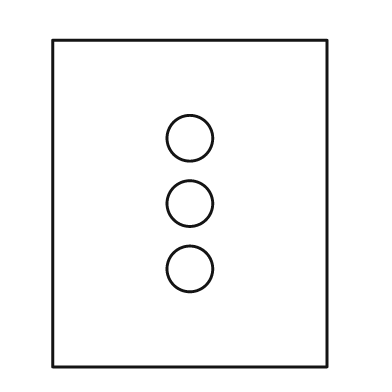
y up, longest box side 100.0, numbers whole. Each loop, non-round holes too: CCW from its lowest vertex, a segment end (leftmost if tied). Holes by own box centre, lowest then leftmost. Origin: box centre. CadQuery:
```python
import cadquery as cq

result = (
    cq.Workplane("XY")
    .moveTo(-42.0, -50.0)
    .lineTo(42.0, -50.0)
    .lineTo(42.0, 50.0)
    .lineTo(-42.0, 50.0)
    .close()
    .moveTo(0.0, -20.0)
    .circle(7.0)
    .moveTo(0.0, 0.0)
    .circle(7.0)
    .moveTo(0.0, 20.0)
    .circle(7.0)
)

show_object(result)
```